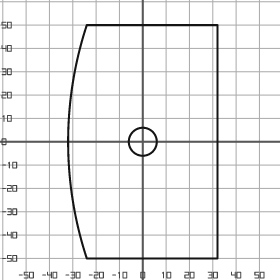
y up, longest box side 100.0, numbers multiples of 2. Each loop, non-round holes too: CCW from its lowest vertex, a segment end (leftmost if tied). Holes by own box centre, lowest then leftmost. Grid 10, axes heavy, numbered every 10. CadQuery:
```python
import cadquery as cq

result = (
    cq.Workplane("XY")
    .moveTo(-24.0, -50.0)
    .lineTo(32.0, -50.0)
    .lineTo(32.0, 50.0)
    .lineTo(-24.0, 50.0)
    .threePointArc((-32.0, 0.0), (-24.0, -50.0))
    .close()
    .moveTo(0.0, 0.0)
    .circle(6.0)
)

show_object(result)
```